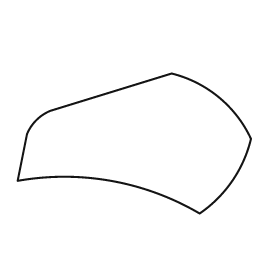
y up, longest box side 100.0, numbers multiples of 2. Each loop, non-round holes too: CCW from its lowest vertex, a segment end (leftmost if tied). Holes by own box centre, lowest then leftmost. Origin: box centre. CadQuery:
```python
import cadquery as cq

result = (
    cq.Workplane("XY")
    .moveTo(28.0, -30.0)
    .threePointArc((42.0, -16.0), (50.0, 2.0))
    .threePointArc((36.0, 20.0), (16.0, 30.0))
    .lineTo(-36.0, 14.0)
    .threePointArc((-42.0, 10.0), (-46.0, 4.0))
    .lineTo(-50.0, -16.0)
    .threePointArc((-10.0, -16.0), (28.0, -30.0))
    .close()
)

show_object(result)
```